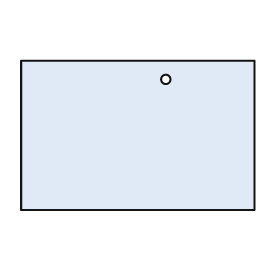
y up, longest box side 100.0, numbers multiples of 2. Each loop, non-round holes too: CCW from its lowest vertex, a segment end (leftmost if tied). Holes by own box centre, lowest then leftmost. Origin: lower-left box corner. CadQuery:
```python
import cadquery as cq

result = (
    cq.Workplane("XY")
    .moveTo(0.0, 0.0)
    .lineTo(100.0, 0.0)
    .lineTo(100.0, 64.0)
    .lineTo(0.0, 64.0)
    .close()
    .moveTo(62.0, 56.0)
    .circle(2.0)
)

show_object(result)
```